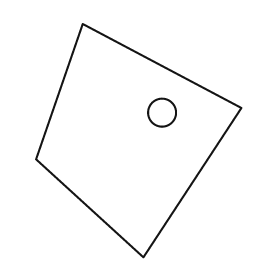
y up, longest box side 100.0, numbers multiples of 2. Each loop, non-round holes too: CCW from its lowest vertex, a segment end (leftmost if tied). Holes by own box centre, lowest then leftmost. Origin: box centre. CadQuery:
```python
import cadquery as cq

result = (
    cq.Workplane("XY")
    .moveTo(2.0, -50.0)
    .lineTo(44.0, 14.0)
    .lineTo(-24.0, 50.0)
    .lineTo(-44.0, -8.0)
    .close()
    .moveTo(10.0, 12.0)
    .circle(6.0)
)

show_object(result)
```